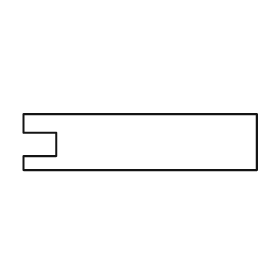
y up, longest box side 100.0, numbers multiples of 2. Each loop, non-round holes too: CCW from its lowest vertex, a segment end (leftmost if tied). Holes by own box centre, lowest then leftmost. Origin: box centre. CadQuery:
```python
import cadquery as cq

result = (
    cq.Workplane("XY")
    .moveTo(-50.0, -12.0)
    .lineTo(50.0, -12.0)
    .lineTo(50.0, 12.0)
    .lineTo(-50.0, 12.0)
    .lineTo(-50.0, 4.0)
    .lineTo(-36.0, 4.0)
    .lineTo(-36.0, -6.0)
    .lineTo(-50.0, -6.0)
    .close()
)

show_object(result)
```